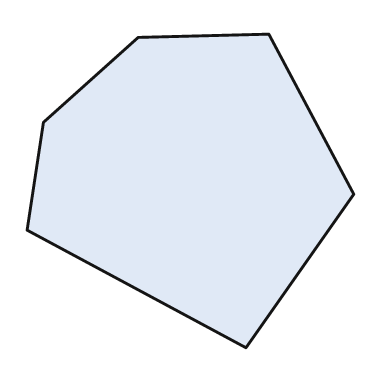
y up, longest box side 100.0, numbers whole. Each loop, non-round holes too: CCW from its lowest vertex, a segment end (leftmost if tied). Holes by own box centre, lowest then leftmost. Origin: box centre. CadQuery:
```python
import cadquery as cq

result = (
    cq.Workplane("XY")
    .moveTo(17.0, -48.0)
    .lineTo(50.0, -1.0)
    .lineTo(24.0, 48.0)
    .lineTo(-16.0, 47.0)
    .lineTo(-45.0, 21.0)
    .lineTo(-50.0, -12.0)
    .close()
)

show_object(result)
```